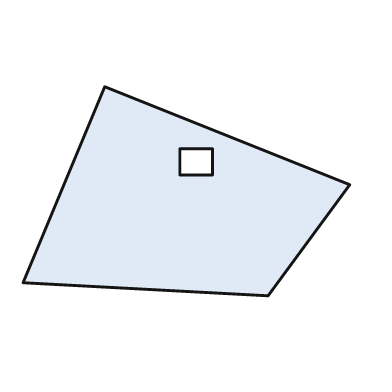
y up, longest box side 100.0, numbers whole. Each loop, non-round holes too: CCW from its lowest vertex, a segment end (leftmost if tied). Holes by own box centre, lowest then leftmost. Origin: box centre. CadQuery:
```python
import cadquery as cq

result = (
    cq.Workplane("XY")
    .moveTo(25.0, -32.0)
    .lineTo(50.0, 2.0)
    .lineTo(-25.0, 32.0)
    .lineTo(-50.0, -28.0)
    .close()
    .moveTo(-2.0, 5.0)
    .lineTo(8.0, 5.0)
    .lineTo(8.0, 13.0)
    .lineTo(-2.0, 13.0)
    .close()
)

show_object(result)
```